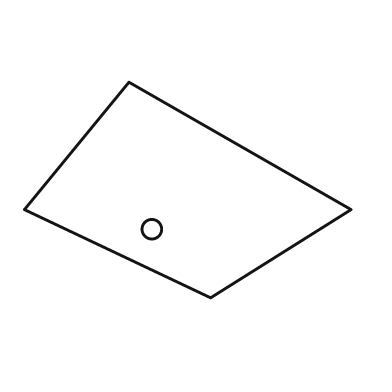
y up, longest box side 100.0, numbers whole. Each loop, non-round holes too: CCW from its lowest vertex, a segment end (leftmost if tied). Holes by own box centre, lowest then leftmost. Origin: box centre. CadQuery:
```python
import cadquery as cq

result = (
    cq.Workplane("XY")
    .moveTo(7.0, -33.0)
    .lineTo(50.0, -6.0)
    .lineTo(-18.0, 33.0)
    .lineTo(-50.0, -6.0)
    .close()
    .moveTo(-11.0, -12.0)
    .circle(3.0)
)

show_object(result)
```